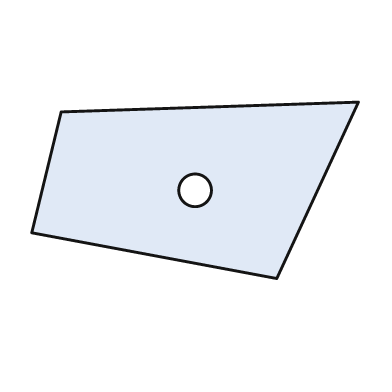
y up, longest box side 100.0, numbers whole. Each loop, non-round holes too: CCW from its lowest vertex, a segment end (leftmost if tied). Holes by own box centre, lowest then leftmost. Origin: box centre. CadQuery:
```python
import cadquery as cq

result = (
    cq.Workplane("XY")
    .moveTo(25.0, -27.0)
    .lineTo(50.0, 27.0)
    .lineTo(-41.0, 24.0)
    .lineTo(-50.0, -13.0)
    .close()
    .moveTo(0.0, 0.0)
    .circle(5.0)
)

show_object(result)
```